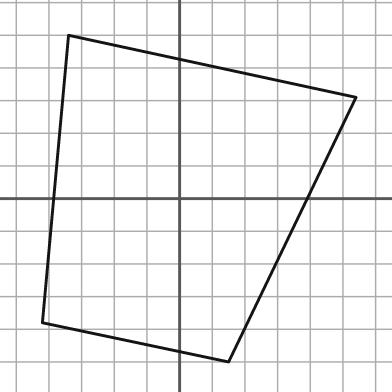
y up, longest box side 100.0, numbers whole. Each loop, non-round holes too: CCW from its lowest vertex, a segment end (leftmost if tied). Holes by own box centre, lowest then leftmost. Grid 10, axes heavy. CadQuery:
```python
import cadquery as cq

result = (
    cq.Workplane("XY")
    .moveTo(15.0, -50.0)
    .lineTo(54.0, 31.0)
    .lineTo(-34.0, 50.0)
    .lineTo(-42.0, -38.0)
    .close()
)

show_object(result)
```